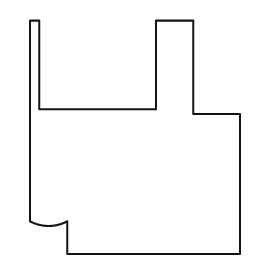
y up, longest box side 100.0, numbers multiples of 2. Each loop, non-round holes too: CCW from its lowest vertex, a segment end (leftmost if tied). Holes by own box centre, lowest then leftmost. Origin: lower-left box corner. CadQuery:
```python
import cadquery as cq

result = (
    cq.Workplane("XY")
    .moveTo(16.0, 0.0)
    .lineTo(90.0, 0.0)
    .lineTo(90.0, 60.0)
    .lineTo(70.0, 60.0)
    .lineTo(70.0, 100.0)
    .lineTo(54.0, 100.0)
    .lineTo(54.0, 62.0)
    .lineTo(4.0, 62.0)
    .lineTo(4.0, 100.0)
    .lineTo(0.0, 100.0)
    .lineTo(0.0, 14.0)
    .threePointArc((8.0, 12.0), (16.0, 14.0))
    .close()
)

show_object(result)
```